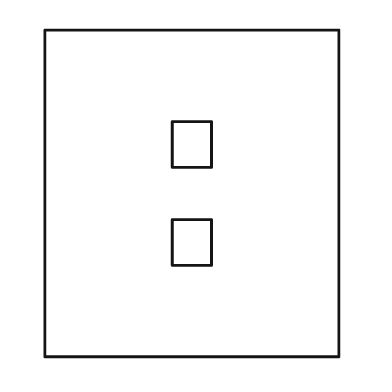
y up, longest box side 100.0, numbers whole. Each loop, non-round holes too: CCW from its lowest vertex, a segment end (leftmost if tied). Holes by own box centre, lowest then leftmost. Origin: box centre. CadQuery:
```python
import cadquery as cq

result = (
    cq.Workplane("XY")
    .moveTo(-45.0, -50.0)
    .lineTo(45.0, -50.0)
    .lineTo(45.0, 50.0)
    .lineTo(-45.0, 50.0)
    .close()
    .moveTo(-6.0, -22.0)
    .lineTo(6.0, -22.0)
    .lineTo(6.0, -8.0)
    .lineTo(-6.0, -8.0)
    .close()
    .moveTo(-6.0, 8.0)
    .lineTo(6.0, 8.0)
    .lineTo(6.0, 22.0)
    .lineTo(-6.0, 22.0)
    .close()
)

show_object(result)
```